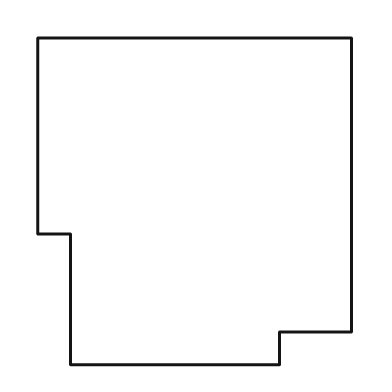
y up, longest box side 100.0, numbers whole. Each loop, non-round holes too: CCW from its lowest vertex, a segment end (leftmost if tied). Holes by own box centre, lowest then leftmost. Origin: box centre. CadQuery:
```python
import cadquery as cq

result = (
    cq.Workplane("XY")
    .moveTo(-38.0, -50.0)
    .lineTo(26.0, -50.0)
    .lineTo(26.0, -40.0)
    .lineTo(48.0, -40.0)
    .lineTo(48.0, 50.0)
    .lineTo(-48.0, 50.0)
    .lineTo(-48.0, -10.0)
    .lineTo(-38.0, -10.0)
    .close()
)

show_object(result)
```